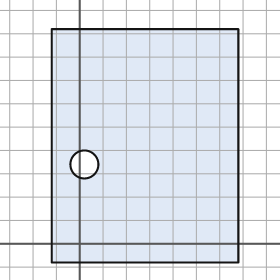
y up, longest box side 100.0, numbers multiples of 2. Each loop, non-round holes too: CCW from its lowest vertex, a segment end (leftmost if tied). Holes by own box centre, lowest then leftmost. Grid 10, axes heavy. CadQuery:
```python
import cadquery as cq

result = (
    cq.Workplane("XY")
    .moveTo(-12.0, -8.0)
    .lineTo(68.0, -8.0)
    .lineTo(68.0, 92.0)
    .lineTo(-12.0, 92.0)
    .close()
    .moveTo(2.0, 34.0)
    .circle(6.0)
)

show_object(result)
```